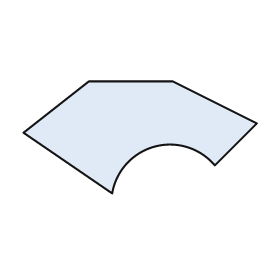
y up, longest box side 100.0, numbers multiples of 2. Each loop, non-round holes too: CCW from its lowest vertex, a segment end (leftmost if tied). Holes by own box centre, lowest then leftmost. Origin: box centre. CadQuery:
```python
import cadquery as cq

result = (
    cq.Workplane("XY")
    .moveTo(-12.0, -24.0)
    .threePointArc((6.0, -4.0), (32.0, -12.0))
    .lineTo(50.0, 6.0)
    .lineTo(14.0, 24.0)
    .lineTo(-22.0, 24.0)
    .lineTo(-50.0, 2.0)
    .close()
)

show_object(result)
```